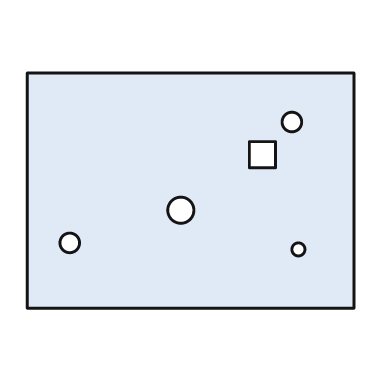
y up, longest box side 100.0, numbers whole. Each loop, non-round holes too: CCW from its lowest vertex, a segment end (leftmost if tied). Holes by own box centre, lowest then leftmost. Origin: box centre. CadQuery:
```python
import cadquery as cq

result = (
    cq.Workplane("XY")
    .moveTo(-50.0, -36.0)
    .lineTo(50.0, -36.0)
    .lineTo(50.0, 36.0)
    .lineTo(-50.0, 36.0)
    .close()
    .moveTo(33.0, -18.0)
    .circle(2.0)
    .moveTo(-37.0, -16.0)
    .circle(3.0)
    .moveTo(-3.0, -6.0)
    .circle(4.0)
    .moveTo(18.0, 7.0)
    .lineTo(26.0, 7.0)
    .lineTo(26.0, 15.0)
    .lineTo(18.0, 15.0)
    .close()
    .moveTo(31.0, 21.0)
    .circle(3.0)
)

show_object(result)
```